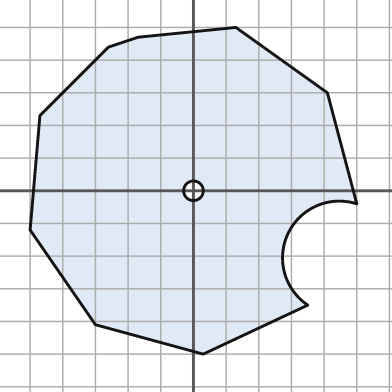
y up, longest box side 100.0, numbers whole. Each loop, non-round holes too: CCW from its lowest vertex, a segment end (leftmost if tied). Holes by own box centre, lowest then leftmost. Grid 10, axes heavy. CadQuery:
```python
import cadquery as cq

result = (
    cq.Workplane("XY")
    .moveTo(3.0, -50.0)
    .lineTo(35.0, -35.0)
    .threePointArc((29.0, -13.0), (50.0, -4.0))
    .lineTo(41.0, 30.0)
    .lineTo(13.0, 50.0)
    .lineTo(-17.0, 47.0)
    .lineTo(-26.0, 44.0)
    .lineTo(-47.0, 23.0)
    .lineTo(-50.0, -12.0)
    .lineTo(-30.0, -41.0)
    .close()
    .moveTo(0.0, 0.0)
    .circle(3.0)
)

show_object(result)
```